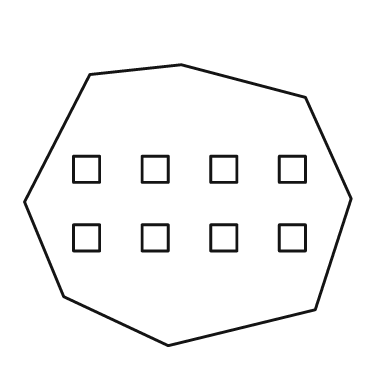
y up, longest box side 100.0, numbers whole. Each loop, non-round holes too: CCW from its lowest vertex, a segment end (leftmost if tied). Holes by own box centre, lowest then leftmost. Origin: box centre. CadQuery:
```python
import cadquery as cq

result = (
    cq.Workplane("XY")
    .moveTo(-6.0, -43.0)
    .lineTo(39.0, -32.0)
    .lineTo(50.0, 2.0)
    .lineTo(36.0, 33.0)
    .lineTo(-2.0, 43.0)
    .lineTo(-30.0, 40.0)
    .lineTo(-50.0, 1.0)
    .lineTo(-38.0, -28.0)
    .close()
    .moveTo(-35.0, -14.0)
    .lineTo(-27.0, -14.0)
    .lineTo(-27.0, -6.0)
    .lineTo(-35.0, -6.0)
    .close()
    .moveTo(-14.0, -14.0)
    .lineTo(-6.0, -14.0)
    .lineTo(-6.0, -6.0)
    .lineTo(-14.0, -6.0)
    .close()
    .moveTo(7.0, -14.0)
    .lineTo(15.0, -14.0)
    .lineTo(15.0, -6.0)
    .lineTo(7.0, -6.0)
    .close()
    .moveTo(28.0, -14.0)
    .lineTo(36.0, -14.0)
    .lineTo(36.0, -6.0)
    .lineTo(28.0, -6.0)
    .close()
    .moveTo(-35.0, 7.0)
    .lineTo(-27.0, 7.0)
    .lineTo(-27.0, 15.0)
    .lineTo(-35.0, 15.0)
    .close()
    .moveTo(-14.0, 7.0)
    .lineTo(-6.0, 7.0)
    .lineTo(-6.0, 15.0)
    .lineTo(-14.0, 15.0)
    .close()
    .moveTo(7.0, 7.0)
    .lineTo(15.0, 7.0)
    .lineTo(15.0, 15.0)
    .lineTo(7.0, 15.0)
    .close()
    .moveTo(28.0, 7.0)
    .lineTo(36.0, 7.0)
    .lineTo(36.0, 15.0)
    .lineTo(28.0, 15.0)
    .close()
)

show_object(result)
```